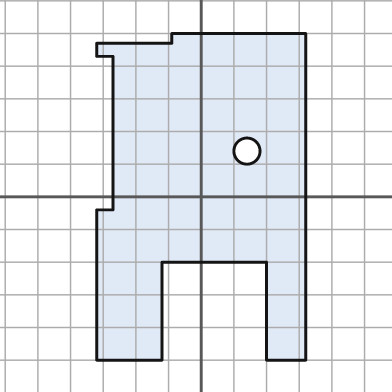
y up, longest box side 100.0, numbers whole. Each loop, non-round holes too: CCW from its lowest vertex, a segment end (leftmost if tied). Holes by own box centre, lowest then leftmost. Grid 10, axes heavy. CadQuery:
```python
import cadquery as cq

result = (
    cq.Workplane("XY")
    .moveTo(-32.0, -50.0)
    .lineTo(-12.0, -50.0)
    .lineTo(-12.0, -20.0)
    .lineTo(20.0, -20.0)
    .lineTo(20.0, -50.0)
    .lineTo(32.0, -50.0)
    .lineTo(32.0, 50.0)
    .lineTo(-9.0, 50.0)
    .lineTo(-9.0, 47.0)
    .lineTo(-32.0, 47.0)
    .lineTo(-32.0, 43.0)
    .lineTo(-27.0, 43.0)
    .lineTo(-27.0, -4.0)
    .lineTo(-32.0, -4.0)
    .close()
    .moveTo(14.0, 14.0)
    .circle(4.0)
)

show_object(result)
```